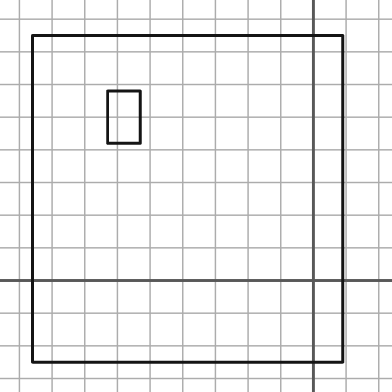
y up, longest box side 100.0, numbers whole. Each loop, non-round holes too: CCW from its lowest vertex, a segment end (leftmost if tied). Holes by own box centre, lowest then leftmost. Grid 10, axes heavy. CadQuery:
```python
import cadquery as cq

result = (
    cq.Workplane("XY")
    .moveTo(-86.0, -25.0)
    .lineTo(9.0, -25.0)
    .lineTo(9.0, 75.0)
    .lineTo(-86.0, 75.0)
    .close()
    .moveTo(-63.0, 42.0)
    .lineTo(-53.0, 42.0)
    .lineTo(-53.0, 58.0)
    .lineTo(-63.0, 58.0)
    .close()
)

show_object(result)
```